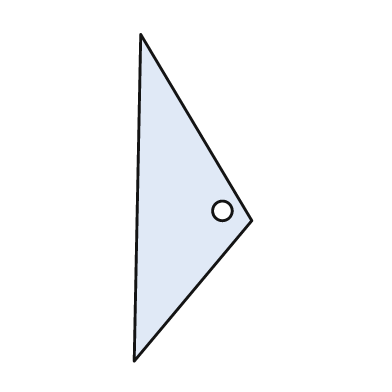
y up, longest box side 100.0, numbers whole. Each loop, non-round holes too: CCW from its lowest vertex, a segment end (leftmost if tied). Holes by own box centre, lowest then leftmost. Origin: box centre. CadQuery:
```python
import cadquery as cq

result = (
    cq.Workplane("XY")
    .moveTo(-18.0, -50.0)
    .lineTo(18.0, -7.0)
    .lineTo(-16.0, 50.0)
    .close()
    .moveTo(9.0, -4.0)
    .circle(3.0)
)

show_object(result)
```